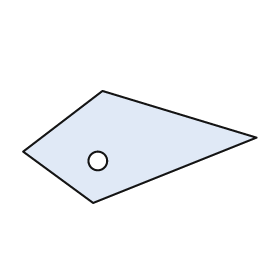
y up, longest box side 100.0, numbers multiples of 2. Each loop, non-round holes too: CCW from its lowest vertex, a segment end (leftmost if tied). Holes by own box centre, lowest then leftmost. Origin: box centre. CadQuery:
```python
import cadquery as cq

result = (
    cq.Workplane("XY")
    .moveTo(-20.0, -24.0)
    .lineTo(50.0, 4.0)
    .lineTo(-16.0, 24.0)
    .lineTo(-50.0, -2.0)
    .close()
    .moveTo(-18.0, -6.0)
    .circle(4.0)
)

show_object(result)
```